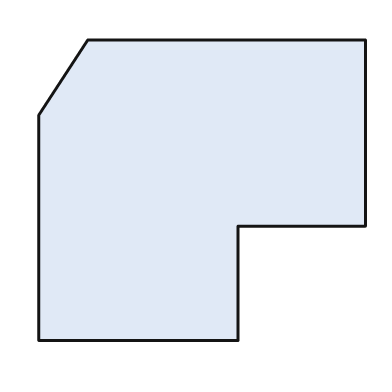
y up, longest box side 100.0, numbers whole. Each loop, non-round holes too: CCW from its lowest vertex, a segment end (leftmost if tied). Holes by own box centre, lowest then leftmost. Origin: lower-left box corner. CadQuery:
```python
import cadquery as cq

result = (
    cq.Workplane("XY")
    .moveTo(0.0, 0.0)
    .lineTo(61.0, 0.0)
    .lineTo(61.0, 35.0)
    .lineTo(100.0, 35.0)
    .lineTo(100.0, 92.0)
    .lineTo(15.0, 92.0)
    .lineTo(0.0, 69.0)
    .close()
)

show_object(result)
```